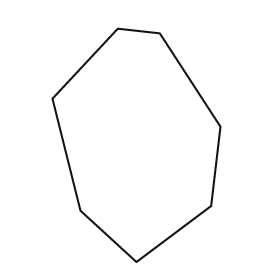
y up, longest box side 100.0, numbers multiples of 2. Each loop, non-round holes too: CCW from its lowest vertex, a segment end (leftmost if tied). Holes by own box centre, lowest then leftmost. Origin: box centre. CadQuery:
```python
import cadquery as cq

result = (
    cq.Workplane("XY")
    .moveTo(0.0, -50.0)
    .lineTo(32.0, -26.0)
    .lineTo(36.0, 8.0)
    .lineTo(10.0, 48.0)
    .lineTo(-8.0, 50.0)
    .lineTo(-36.0, 20.0)
    .lineTo(-24.0, -28.0)
    .close()
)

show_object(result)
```